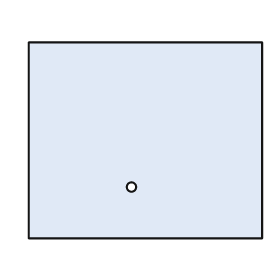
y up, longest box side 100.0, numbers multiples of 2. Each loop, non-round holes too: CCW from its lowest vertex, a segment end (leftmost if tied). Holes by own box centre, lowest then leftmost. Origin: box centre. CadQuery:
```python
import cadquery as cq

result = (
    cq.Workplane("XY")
    .moveTo(-50.0, -42.0)
    .lineTo(50.0, -42.0)
    .lineTo(50.0, 42.0)
    .lineTo(-50.0, 42.0)
    .close()
    .moveTo(-6.0, -20.0)
    .circle(2.0)
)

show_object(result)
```